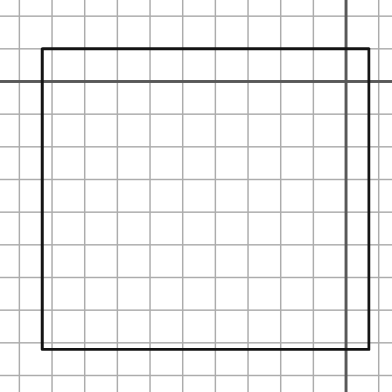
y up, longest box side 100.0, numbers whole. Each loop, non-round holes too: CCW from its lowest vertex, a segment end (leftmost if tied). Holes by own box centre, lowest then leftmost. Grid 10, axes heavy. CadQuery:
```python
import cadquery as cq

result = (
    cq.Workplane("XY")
    .moveTo(-93.0, -82.0)
    .lineTo(7.0, -82.0)
    .lineTo(7.0, 10.0)
    .lineTo(-93.0, 10.0)
    .close()
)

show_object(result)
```